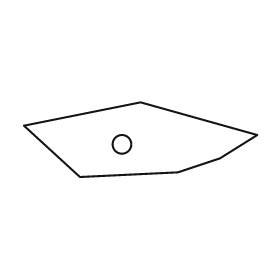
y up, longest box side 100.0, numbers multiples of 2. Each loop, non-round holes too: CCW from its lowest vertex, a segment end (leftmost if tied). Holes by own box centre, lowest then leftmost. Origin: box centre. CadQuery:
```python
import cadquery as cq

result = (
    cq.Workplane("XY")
    .moveTo(-26.0, -16.0)
    .lineTo(16.0, -14.0)
    .lineTo(34.0, -8.0)
    .lineTo(50.0, 2.0)
    .lineTo(0.0, 16.0)
    .lineTo(-50.0, 6.0)
    .close()
    .moveTo(-8.0, -2.0)
    .circle(4.0)
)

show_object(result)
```